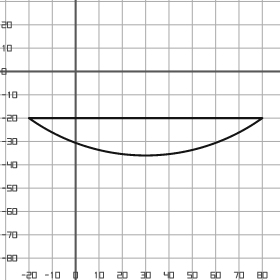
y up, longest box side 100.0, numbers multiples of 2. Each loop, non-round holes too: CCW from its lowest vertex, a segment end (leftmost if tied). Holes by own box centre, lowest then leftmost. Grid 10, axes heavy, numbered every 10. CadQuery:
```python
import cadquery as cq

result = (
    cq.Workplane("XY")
    .moveTo(-20.0, -20.0)
    .threePointArc((30.0, -36.0), (80.0, -20.0))
    .close()
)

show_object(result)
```